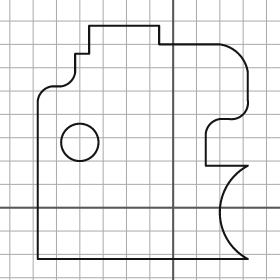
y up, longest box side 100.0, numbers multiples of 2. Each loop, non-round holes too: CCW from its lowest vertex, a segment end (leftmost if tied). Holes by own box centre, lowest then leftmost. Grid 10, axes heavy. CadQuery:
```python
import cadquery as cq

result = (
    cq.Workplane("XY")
    .moveTo(-58.0, -22.0)
    .lineTo(32.0, -22.0)
    .threePointArc((20.0, -2.0), (32.0, 18.0))
    .lineTo(14.0, 18.0)
    .lineTo(14.0, 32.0)
    .threePointArc((16.0, 36.0), (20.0, 38.0))
    .lineTo(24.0, 38.0)
    .threePointArc((30.0, 40.0), (32.0, 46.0))
    .lineTo(32.0, 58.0)
    .threePointArc((28.0, 66.0), (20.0, 70.0))
    .lineTo(-6.0, 70.0)
    .lineTo(-6.0, 78.0)
    .lineTo(-36.0, 78.0)
    .lineTo(-36.0, 66.0)
    .lineTo(-42.0, 66.0)
    .lineTo(-42.0, 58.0)
    .threePointArc((-44.0, 54.0), (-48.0, 52.0))
    .lineTo(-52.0, 52.0)
    .threePointArc((-56.0, 50.0), (-58.0, 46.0))
    .close()
    .moveTo(-40.0, 28.0)
    .circle(8.0)
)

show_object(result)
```